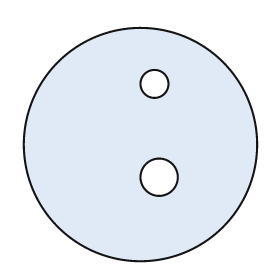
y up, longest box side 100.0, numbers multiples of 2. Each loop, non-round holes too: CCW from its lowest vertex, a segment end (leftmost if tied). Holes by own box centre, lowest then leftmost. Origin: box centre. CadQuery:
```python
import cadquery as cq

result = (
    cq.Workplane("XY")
    .moveTo(0.0, 0.0)
    .circle(50.0)
    .moveTo(8.0, -14.0)
    .circle(8.0)
    .moveTo(6.0, 26.0)
    .circle(6.0)
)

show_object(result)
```